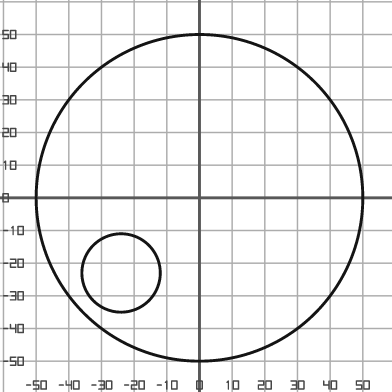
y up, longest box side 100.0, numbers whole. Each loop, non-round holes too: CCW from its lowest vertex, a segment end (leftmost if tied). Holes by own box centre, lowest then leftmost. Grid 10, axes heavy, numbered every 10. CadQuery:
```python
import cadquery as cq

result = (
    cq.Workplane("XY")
    .moveTo(0.0, 0.0)
    .circle(50.0)
    .moveTo(-24.0, -23.0)
    .circle(12.0)
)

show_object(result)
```